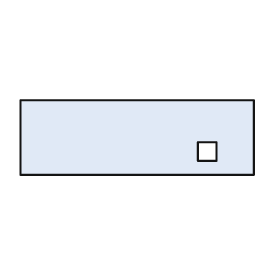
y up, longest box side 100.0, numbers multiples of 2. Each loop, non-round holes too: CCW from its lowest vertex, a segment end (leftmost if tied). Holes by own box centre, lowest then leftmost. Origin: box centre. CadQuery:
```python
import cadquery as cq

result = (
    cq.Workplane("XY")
    .moveTo(-50.0, -16.0)
    .lineTo(50.0, -16.0)
    .lineTo(50.0, 16.0)
    .lineTo(-50.0, 16.0)
    .close()
    .moveTo(26.0, -10.0)
    .lineTo(34.0, -10.0)
    .lineTo(34.0, -2.0)
    .lineTo(26.0, -2.0)
    .close()
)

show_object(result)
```